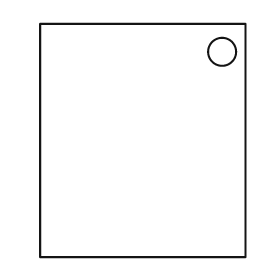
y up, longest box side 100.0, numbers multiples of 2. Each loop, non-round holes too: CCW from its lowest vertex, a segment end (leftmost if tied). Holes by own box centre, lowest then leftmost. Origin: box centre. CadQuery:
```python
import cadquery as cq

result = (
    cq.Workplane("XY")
    .moveTo(-44.0, -50.0)
    .lineTo(44.0, -50.0)
    .lineTo(44.0, 50.0)
    .lineTo(-44.0, 50.0)
    .close()
    .moveTo(34.0, 38.0)
    .circle(6.0)
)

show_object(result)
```